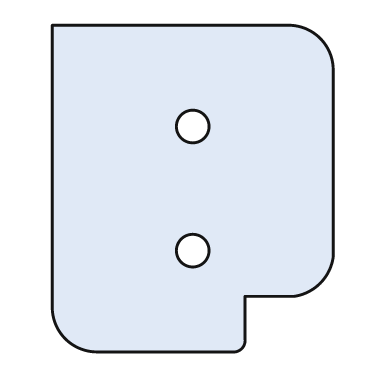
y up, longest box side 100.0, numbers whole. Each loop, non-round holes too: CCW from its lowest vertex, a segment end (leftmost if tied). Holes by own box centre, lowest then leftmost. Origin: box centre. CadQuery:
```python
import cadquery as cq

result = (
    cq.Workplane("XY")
    .moveTo(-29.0, -50.0)
    .lineTo(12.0, -50.0)
    .threePointArc((15.0, -49.0), (16.0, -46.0))
    .lineTo(16.0, -33.0)
    .lineTo(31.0, -33.0)
    .threePointArc((39.0, -29.0), (43.0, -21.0))
    .lineTo(43.0, 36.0)
    .threePointArc((39.0, 46.0), (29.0, 50.0))
    .lineTo(-43.0, 50.0)
    .lineTo(-43.0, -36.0)
    .threePointArc((-39.0, -46.0), (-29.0, -50.0))
    .close()
    .moveTo(0.0, -19.0)
    .circle(5.0)
    .moveTo(0.0, 19.0)
    .circle(5.0)
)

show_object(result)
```